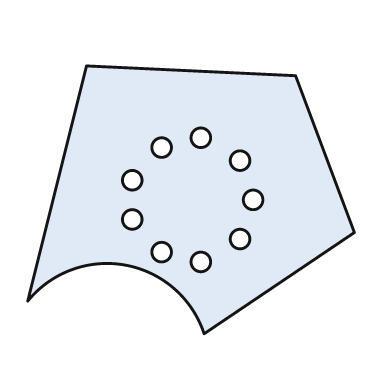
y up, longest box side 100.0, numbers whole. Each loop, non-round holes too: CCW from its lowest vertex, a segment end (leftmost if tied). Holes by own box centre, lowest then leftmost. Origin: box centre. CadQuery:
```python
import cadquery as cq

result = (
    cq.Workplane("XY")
    .moveTo(4.0, -41.0)
    .lineTo(50.0, -10.0)
    .lineTo(32.0, 38.0)
    .lineTo(-32.0, 41.0)
    .lineTo(-50.0, -31.0)
    .threePointArc((-20.0, -20.0), (4.0, -41.0))
    .close()
    .moveTo(3.0, -19.0)
    .circle(3.0)
    .moveTo(-9.0, -16.0)
    .circle(3.0)
    .moveTo(15.0, -12.0)
    .circle(3.0)
    .moveTo(-18.0, -6.0)
    .circle(3.0)
    .moveTo(19.0, 0.0)
    .circle(3.0)
    .moveTo(-18.0, 6.0)
    .circle(3.0)
    .moveTo(15.0, 12.0)
    .circle(3.0)
    .moveTo(-9.0, 16.0)
    .circle(3.0)
    .moveTo(3.0, 19.0)
    .circle(3.0)
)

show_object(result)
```